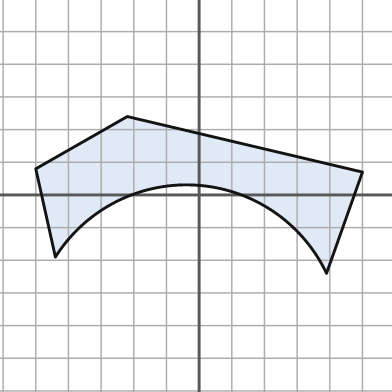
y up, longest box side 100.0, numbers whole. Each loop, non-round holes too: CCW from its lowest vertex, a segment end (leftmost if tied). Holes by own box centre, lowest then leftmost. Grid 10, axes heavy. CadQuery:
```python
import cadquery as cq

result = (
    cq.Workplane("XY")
    .moveTo(39.0, -24.0)
    .lineTo(50.0, 7.0)
    .lineTo(-22.0, 24.0)
    .lineTo(-50.0, 8.0)
    .lineTo(-44.0, -19.0)
    .threePointArc((-1.0, 3.0), (39.0, -24.0))
    .close()
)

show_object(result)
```